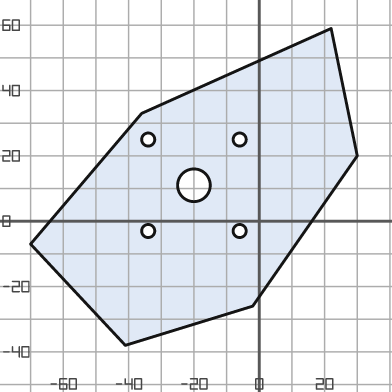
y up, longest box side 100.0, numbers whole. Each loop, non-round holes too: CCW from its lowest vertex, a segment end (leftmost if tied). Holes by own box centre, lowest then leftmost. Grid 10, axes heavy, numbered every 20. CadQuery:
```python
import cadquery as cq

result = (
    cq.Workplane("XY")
    .moveTo(-41.0, -38.0)
    .lineTo(-2.0, -26.0)
    .lineTo(30.0, 20.0)
    .lineTo(22.0, 59.0)
    .lineTo(-36.0, 33.0)
    .lineTo(-70.0, -7.0)
    .close()
    .moveTo(-34.0, -3.0)
    .circle(2.0)
    .moveTo(-6.0, -3.0)
    .circle(2.0)
    .moveTo(-20.0, 11.0)
    .circle(5.0)
    .moveTo(-34.0, 25.0)
    .circle(2.0)
    .moveTo(-6.0, 25.0)
    .circle(2.0)
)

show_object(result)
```